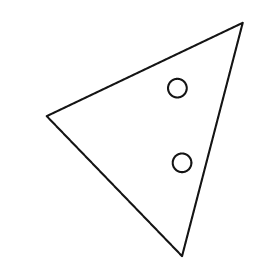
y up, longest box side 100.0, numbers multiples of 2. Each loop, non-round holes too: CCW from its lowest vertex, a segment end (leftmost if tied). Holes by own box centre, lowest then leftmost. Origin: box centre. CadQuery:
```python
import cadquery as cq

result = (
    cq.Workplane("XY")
    .moveTo(16.0, -50.0)
    .lineTo(42.0, 50.0)
    .lineTo(-42.0, 10.0)
    .close()
    .moveTo(16.0, -10.0)
    .circle(4.0)
    .moveTo(14.0, 22.0)
    .circle(4.0)
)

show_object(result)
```